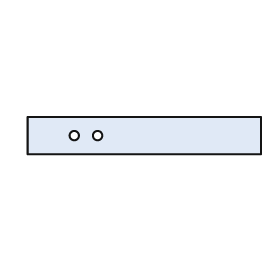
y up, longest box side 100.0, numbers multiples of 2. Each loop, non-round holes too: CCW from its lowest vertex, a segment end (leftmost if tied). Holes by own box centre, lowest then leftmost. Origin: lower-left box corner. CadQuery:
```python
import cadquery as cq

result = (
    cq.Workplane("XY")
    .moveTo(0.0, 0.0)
    .lineTo(100.0, 0.0)
    .lineTo(100.0, 16.0)
    .lineTo(0.0, 16.0)
    .close()
    .moveTo(20.0, 8.0)
    .circle(2.0)
    .moveTo(30.0, 8.0)
    .circle(2.0)
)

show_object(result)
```